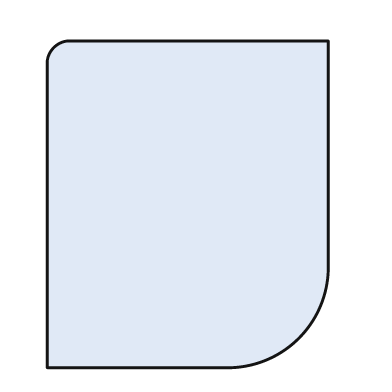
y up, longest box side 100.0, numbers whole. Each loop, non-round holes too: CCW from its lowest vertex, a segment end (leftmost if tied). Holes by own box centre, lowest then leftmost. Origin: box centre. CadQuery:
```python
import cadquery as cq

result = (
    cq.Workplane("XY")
    .moveTo(-43.0, -50.0)
    .lineTo(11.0, -50.0)
    .threePointArc((34.0, -41.0), (43.0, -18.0))
    .lineTo(43.0, 50.0)
    .lineTo(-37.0, 50.0)
    .threePointArc((-41.0, 48.0), (-43.0, 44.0))
    .close()
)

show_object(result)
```